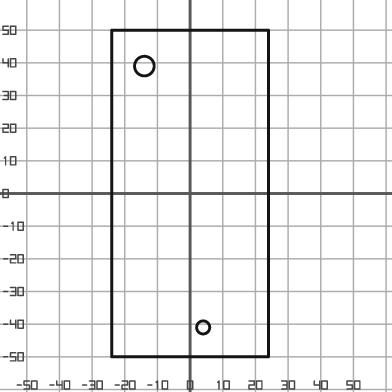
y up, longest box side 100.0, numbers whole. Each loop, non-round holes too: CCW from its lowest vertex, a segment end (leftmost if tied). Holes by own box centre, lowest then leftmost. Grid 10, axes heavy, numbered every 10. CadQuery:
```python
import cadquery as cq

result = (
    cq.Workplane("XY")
    .moveTo(-24.0, -50.0)
    .lineTo(24.0, -50.0)
    .lineTo(24.0, 50.0)
    .lineTo(-24.0, 50.0)
    .close()
    .moveTo(4.0, -41.0)
    .circle(2.0)
    .moveTo(-14.0, 39.0)
    .circle(3.0)
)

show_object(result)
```